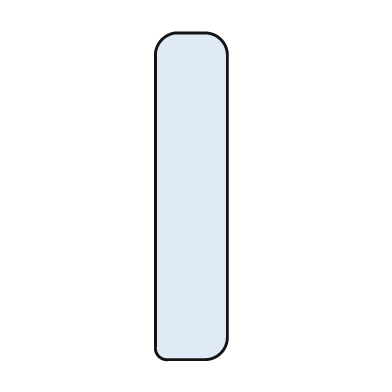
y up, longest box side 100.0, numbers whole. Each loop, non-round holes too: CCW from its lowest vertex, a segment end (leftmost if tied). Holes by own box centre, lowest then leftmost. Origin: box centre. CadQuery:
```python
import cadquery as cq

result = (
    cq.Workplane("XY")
    .moveTo(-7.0, -50.0)
    .lineTo(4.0, -50.0)
    .threePointArc((9.0, -48.0), (11.0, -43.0))
    .lineTo(11.0, 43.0)
    .threePointArc((9.0, 48.0), (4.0, 50.0))
    .lineTo(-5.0, 50.0)
    .threePointArc((-9.0, 48.0), (-11.0, 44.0))
    .lineTo(-11.0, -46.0)
    .threePointArc((-10.0, -49.0), (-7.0, -50.0))
    .close()
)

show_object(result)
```